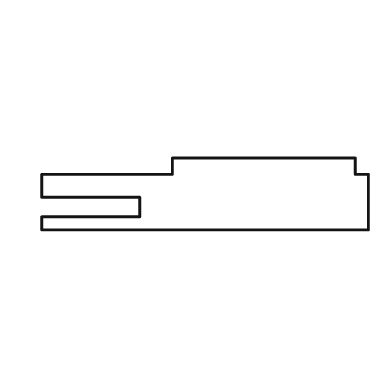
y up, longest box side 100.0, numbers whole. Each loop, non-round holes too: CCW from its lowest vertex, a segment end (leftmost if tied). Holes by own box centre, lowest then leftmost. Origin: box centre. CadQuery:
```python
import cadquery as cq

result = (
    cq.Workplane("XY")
    .moveTo(-50.0, -11.0)
    .lineTo(50.0, -11.0)
    .lineTo(50.0, 6.0)
    .lineTo(46.0, 6.0)
    .lineTo(46.0, 11.0)
    .lineTo(-10.0, 11.0)
    .lineTo(-10.0, 6.0)
    .lineTo(-50.0, 6.0)
    .lineTo(-50.0, -1.0)
    .lineTo(-20.0, -1.0)
    .lineTo(-20.0, -7.0)
    .lineTo(-50.0, -7.0)
    .close()
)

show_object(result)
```